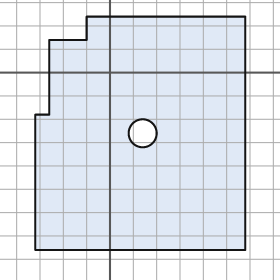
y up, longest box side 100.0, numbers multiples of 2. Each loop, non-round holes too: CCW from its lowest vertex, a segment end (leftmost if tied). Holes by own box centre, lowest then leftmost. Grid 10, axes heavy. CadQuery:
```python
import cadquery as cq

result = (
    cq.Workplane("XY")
    .moveTo(-32.0, -76.0)
    .lineTo(58.0, -76.0)
    .lineTo(58.0, 24.0)
    .lineTo(-10.0, 24.0)
    .lineTo(-10.0, 14.0)
    .lineTo(-26.0, 14.0)
    .lineTo(-26.0, -18.0)
    .lineTo(-32.0, -18.0)
    .close()
    .moveTo(14.0, -26.0)
    .circle(6.0)
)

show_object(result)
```